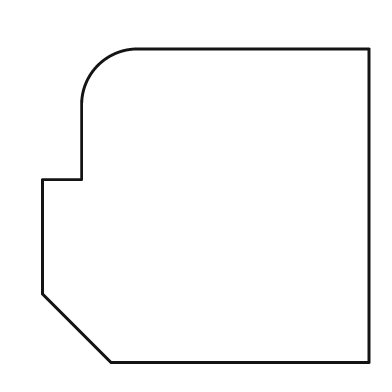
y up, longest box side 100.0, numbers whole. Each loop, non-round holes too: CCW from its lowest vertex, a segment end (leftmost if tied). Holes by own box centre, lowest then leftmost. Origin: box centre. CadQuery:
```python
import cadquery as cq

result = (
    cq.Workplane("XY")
    .moveTo(-29.0, -48.0)
    .lineTo(50.0, -48.0)
    .lineTo(50.0, 48.0)
    .lineTo(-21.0, 48.0)
    .threePointArc((-33.0, 43.0), (-38.0, 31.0))
    .lineTo(-38.0, 8.0)
    .lineTo(-50.0, 8.0)
    .lineTo(-50.0, -27.0)
    .close()
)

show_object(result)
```